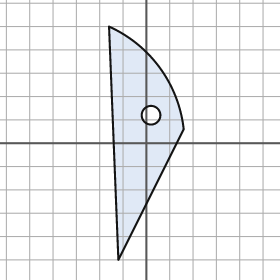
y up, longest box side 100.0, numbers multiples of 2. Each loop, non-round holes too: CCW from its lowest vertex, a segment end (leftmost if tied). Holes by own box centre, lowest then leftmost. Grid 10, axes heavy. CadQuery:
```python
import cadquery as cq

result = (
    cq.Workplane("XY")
    .moveTo(-12.0, -50.0)
    .lineTo(16.0, 6.0)
    .threePointArc((6.0, 32.0), (-16.0, 50.0))
    .close()
    .moveTo(2.0, 12.0)
    .circle(4.0)
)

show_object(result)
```